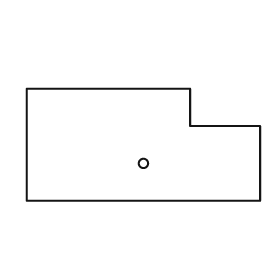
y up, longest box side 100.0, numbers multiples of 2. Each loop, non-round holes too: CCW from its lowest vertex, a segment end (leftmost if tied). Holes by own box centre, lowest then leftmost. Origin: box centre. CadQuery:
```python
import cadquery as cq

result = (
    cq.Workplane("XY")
    .moveTo(-50.0, -24.0)
    .lineTo(50.0, -24.0)
    .lineTo(50.0, 8.0)
    .lineTo(20.0, 8.0)
    .lineTo(20.0, 24.0)
    .lineTo(-50.0, 24.0)
    .close()
    .moveTo(0.0, -8.0)
    .circle(2.0)
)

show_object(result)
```